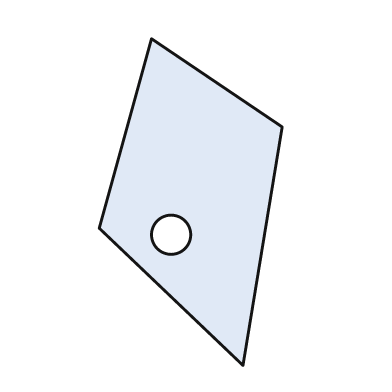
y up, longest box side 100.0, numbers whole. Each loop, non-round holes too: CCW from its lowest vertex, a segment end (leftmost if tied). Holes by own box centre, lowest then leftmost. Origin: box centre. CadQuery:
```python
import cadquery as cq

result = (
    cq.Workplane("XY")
    .moveTo(16.0, -50.0)
    .lineTo(28.0, 23.0)
    .lineTo(-12.0, 50.0)
    .lineTo(-28.0, -8.0)
    .close()
    .moveTo(-6.0, -10.0)
    .circle(6.0)
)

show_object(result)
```